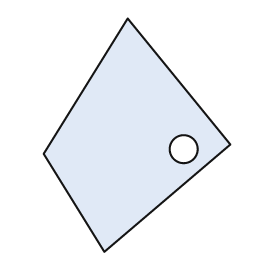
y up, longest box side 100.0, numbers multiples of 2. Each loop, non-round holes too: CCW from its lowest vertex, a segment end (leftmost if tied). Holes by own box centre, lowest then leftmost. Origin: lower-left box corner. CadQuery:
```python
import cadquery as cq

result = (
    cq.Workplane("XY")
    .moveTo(26.0, 0.0)
    .lineTo(80.0, 46.0)
    .lineTo(36.0, 100.0)
    .lineTo(0.0, 42.0)
    .close()
    .moveTo(60.0, 44.0)
    .circle(6.0)
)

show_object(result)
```